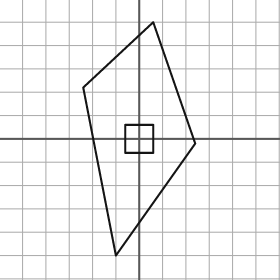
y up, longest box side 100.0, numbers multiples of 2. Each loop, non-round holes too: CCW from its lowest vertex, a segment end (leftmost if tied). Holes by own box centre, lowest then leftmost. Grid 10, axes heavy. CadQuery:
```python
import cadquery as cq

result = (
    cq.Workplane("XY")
    .moveTo(-10.0, -50.0)
    .lineTo(24.0, -2.0)
    .lineTo(6.0, 50.0)
    .lineTo(-24.0, 22.0)
    .close()
    .moveTo(-6.0, -6.0)
    .lineTo(6.0, -6.0)
    .lineTo(6.0, 6.0)
    .lineTo(-6.0, 6.0)
    .close()
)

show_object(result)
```